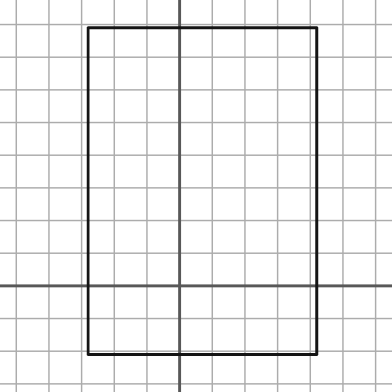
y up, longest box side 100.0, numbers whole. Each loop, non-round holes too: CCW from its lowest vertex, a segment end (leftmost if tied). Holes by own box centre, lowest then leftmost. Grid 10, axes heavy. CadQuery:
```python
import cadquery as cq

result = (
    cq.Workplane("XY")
    .moveTo(-28.0, -21.0)
    .lineTo(42.0, -21.0)
    .lineTo(42.0, 79.0)
    .lineTo(-28.0, 79.0)
    .close()
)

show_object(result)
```